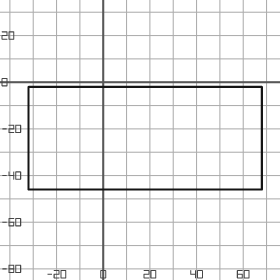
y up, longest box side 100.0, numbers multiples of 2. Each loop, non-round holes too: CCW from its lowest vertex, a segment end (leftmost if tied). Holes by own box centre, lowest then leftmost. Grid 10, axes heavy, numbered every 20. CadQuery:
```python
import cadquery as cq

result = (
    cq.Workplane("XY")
    .moveTo(-32.0, -46.0)
    .lineTo(68.0, -46.0)
    .lineTo(68.0, -2.0)
    .lineTo(-32.0, -2.0)
    .close()
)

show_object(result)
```